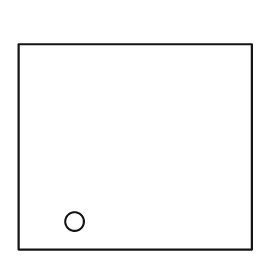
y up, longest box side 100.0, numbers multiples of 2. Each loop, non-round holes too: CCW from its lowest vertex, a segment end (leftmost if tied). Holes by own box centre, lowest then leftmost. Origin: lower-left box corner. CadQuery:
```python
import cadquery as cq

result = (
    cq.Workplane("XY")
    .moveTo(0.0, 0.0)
    .lineTo(100.0, 0.0)
    .lineTo(100.0, 88.0)
    .lineTo(0.0, 88.0)
    .close()
    .moveTo(24.0, 12.0)
    .circle(4.0)
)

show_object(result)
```